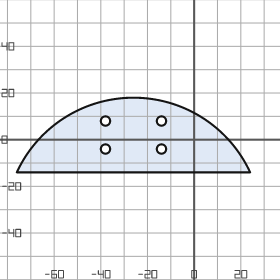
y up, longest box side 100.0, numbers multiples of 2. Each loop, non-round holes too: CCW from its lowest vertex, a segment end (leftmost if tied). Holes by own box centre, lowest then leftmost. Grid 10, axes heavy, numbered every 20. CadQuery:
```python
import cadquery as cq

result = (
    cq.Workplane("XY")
    .moveTo(-76.0, -14.0)
    .lineTo(24.0, -14.0)
    .threePointArc((-26.0, 18.0), (-76.0, -14.0))
    .close()
    .moveTo(-38.0, -4.0)
    .circle(2.0)
    .moveTo(-14.0, -4.0)
    .circle(2.0)
    .moveTo(-38.0, 8.0)
    .circle(2.0)
    .moveTo(-14.0, 8.0)
    .circle(2.0)
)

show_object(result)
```